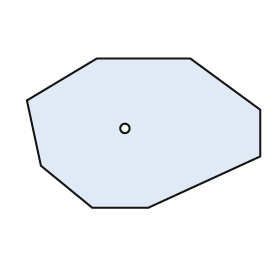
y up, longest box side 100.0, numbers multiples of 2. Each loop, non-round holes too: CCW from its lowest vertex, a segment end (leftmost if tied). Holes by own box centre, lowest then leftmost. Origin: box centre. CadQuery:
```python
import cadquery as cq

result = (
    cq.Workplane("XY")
    .moveTo(-22.0, -32.0)
    .lineTo(2.0, -32.0)
    .lineTo(50.0, -10.0)
    .lineTo(50.0, 10.0)
    .lineTo(20.0, 32.0)
    .lineTo(-20.0, 32.0)
    .lineTo(-50.0, 14.0)
    .lineTo(-44.0, -14.0)
    .close()
    .moveTo(-8.0, 2.0)
    .circle(2.0)
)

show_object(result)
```